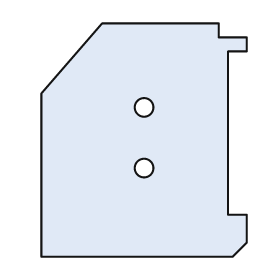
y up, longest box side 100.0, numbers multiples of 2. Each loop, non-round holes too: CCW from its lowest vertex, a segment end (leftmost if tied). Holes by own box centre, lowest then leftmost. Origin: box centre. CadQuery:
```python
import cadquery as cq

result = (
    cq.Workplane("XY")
    .moveTo(-44.0, -50.0)
    .lineTo(38.0, -50.0)
    .lineTo(44.0, -44.0)
    .lineTo(44.0, -32.0)
    .lineTo(36.0, -32.0)
    .lineTo(36.0, 38.0)
    .lineTo(44.0, 38.0)
    .lineTo(44.0, 44.0)
    .lineTo(32.0, 44.0)
    .lineTo(32.0, 50.0)
    .lineTo(-18.0, 50.0)
    .lineTo(-44.0, 20.0)
    .close()
    .moveTo(0.0, -12.0)
    .circle(4.0)
    .moveTo(0.0, 14.0)
    .circle(4.0)
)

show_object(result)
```